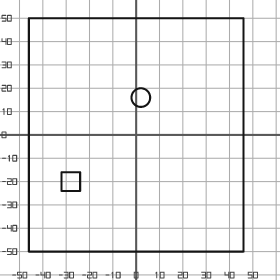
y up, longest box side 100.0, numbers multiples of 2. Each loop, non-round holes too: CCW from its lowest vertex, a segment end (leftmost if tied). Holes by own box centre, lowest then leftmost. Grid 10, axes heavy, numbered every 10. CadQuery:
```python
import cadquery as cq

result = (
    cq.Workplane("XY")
    .moveTo(-46.0, -50.0)
    .lineTo(46.0, -50.0)
    .lineTo(46.0, 50.0)
    .lineTo(-46.0, 50.0)
    .close()
    .moveTo(-32.0, -24.0)
    .lineTo(-24.0, -24.0)
    .lineTo(-24.0, -16.0)
    .lineTo(-32.0, -16.0)
    .close()
    .moveTo(2.0, 16.0)
    .circle(4.0)
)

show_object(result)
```